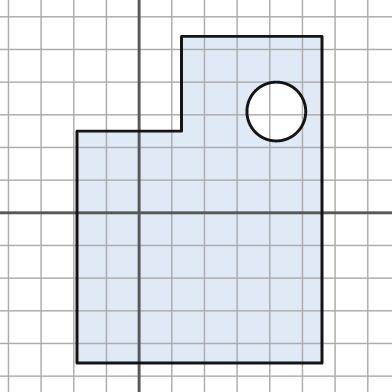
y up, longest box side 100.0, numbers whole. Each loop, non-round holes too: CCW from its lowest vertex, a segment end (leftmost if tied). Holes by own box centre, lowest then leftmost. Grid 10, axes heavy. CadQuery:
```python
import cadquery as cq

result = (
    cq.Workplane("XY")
    .moveTo(-19.0, -46.0)
    .lineTo(56.0, -46.0)
    .lineTo(56.0, 54.0)
    .lineTo(13.0, 54.0)
    .lineTo(13.0, 25.0)
    .lineTo(-19.0, 25.0)
    .close()
    .moveTo(42.0, 31.0)
    .circle(9.0)
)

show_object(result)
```